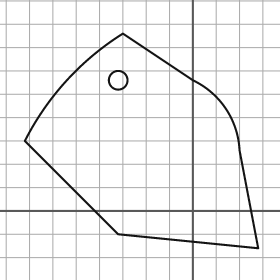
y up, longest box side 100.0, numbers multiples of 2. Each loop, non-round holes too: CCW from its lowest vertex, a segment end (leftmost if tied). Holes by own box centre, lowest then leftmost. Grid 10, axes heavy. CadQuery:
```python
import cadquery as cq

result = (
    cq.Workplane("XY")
    .moveTo(28.0, -16.0)
    .lineTo(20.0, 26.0)
    .threePointArc((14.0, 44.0), (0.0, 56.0))
    .lineTo(-30.0, 76.0)
    .threePointArc((-54.0, 56.0), (-72.0, 30.0))
    .lineTo(-32.0, -10.0)
    .close()
    .moveTo(-32.0, 56.0)
    .circle(4.0)
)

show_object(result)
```